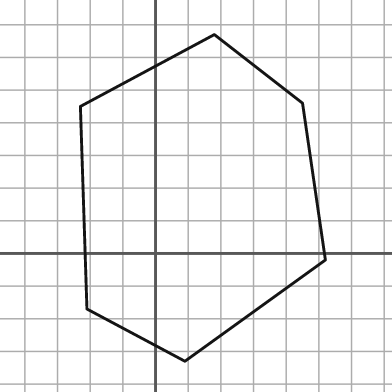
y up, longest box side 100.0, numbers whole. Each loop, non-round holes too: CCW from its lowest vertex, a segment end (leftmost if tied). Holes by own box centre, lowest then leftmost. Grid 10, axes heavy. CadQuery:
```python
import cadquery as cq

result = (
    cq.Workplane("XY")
    .moveTo(9.0, -33.0)
    .lineTo(52.0, -2.0)
    .lineTo(45.0, 46.0)
    .lineTo(18.0, 67.0)
    .lineTo(-23.0, 45.0)
    .lineTo(-21.0, -17.0)
    .close()
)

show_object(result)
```